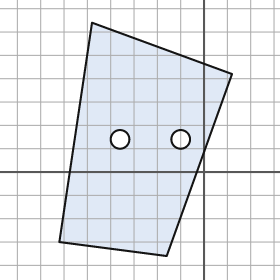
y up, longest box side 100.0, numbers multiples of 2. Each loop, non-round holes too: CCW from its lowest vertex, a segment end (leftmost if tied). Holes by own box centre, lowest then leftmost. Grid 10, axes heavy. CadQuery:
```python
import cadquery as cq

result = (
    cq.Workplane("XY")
    .moveTo(-16.0, -36.0)
    .lineTo(12.0, 42.0)
    .lineTo(-48.0, 64.0)
    .lineTo(-62.0, -30.0)
    .close()
    .moveTo(-36.0, 14.0)
    .circle(4.0)
    .moveTo(-10.0, 14.0)
    .circle(4.0)
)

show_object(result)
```